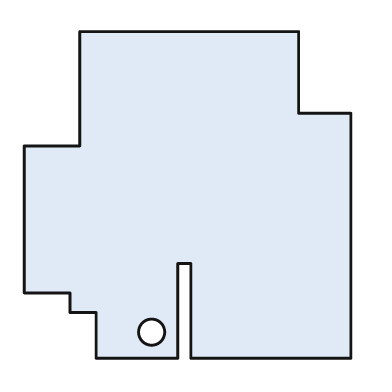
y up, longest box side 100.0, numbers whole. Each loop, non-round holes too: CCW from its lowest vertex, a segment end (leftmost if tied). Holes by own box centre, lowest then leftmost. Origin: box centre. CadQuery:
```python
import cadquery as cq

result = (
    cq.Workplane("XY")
    .moveTo(-28.0, -50.0)
    .lineTo(-3.0, -50.0)
    .lineTo(-3.0, -21.0)
    .lineTo(1.0, -21.0)
    .lineTo(1.0, -50.0)
    .lineTo(50.0, -50.0)
    .lineTo(50.0, 25.0)
    .lineTo(34.0, 25.0)
    .lineTo(34.0, 50.0)
    .lineTo(-33.0, 50.0)
    .lineTo(-33.0, 15.0)
    .lineTo(-50.0, 15.0)
    .lineTo(-50.0, -30.0)
    .lineTo(-36.0, -30.0)
    .lineTo(-36.0, -36.0)
    .lineTo(-28.0, -36.0)
    .close()
    .moveTo(-11.0, -42.0)
    .circle(4.0)
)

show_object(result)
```